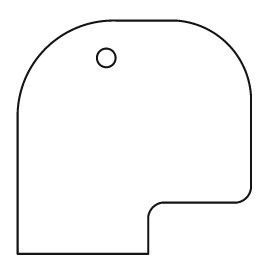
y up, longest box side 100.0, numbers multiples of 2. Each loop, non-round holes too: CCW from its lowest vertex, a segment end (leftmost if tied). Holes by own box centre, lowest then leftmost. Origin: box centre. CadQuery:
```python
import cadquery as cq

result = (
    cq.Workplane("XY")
    .moveTo(-50.0, -50.0)
    .lineTo(6.0, -50.0)
    .lineTo(6.0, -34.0)
    .threePointArc((8.0, -30.0), (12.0, -28.0))
    .lineTo(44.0, -28.0)
    .threePointArc((48.0, -26.0), (50.0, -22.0))
    .lineTo(50.0, 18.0)
    .threePointArc((40.0, 40.0), (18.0, 50.0))
    .lineTo(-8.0, 50.0)
    .threePointArc((-38.0, 38.0), (-50.0, 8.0))
    .close()
    .moveTo(-12.0, 34.0)
    .circle(4.0)
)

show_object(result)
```